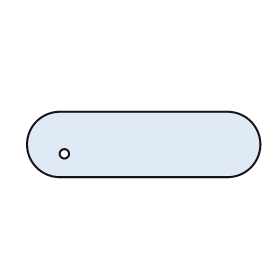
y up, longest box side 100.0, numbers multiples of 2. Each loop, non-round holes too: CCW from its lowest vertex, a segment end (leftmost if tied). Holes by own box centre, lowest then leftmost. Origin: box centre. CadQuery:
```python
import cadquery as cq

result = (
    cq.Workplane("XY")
    .moveTo(-36.0, -14.0)
    .lineTo(36.0, -14.0)
    .threePointArc((50.0, 0.0), (36.0, 14.0))
    .lineTo(-36.0, 14.0)
    .threePointArc((-50.0, 0.0), (-36.0, -14.0))
    .close()
    .moveTo(-34.0, -4.0)
    .circle(2.0)
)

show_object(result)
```